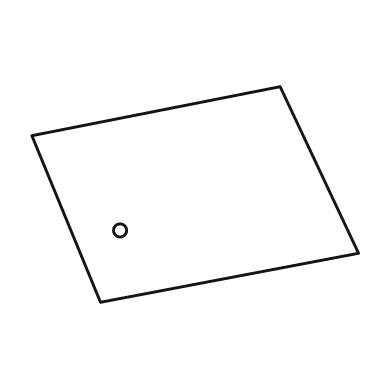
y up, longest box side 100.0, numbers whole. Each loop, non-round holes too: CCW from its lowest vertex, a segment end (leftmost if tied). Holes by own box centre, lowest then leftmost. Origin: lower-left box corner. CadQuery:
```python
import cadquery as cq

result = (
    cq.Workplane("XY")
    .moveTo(21.0, 0.0)
    .lineTo(100.0, 15.0)
    .lineTo(76.0, 66.0)
    .lineTo(0.0, 51.0)
    .close()
    .moveTo(27.0, 22.0)
    .circle(2.0)
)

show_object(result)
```